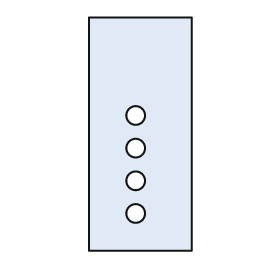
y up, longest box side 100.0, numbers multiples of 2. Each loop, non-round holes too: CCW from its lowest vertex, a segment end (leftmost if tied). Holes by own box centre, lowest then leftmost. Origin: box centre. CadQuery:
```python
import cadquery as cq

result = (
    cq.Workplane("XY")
    .moveTo(-22.0, -50.0)
    .lineTo(22.0, -50.0)
    .lineTo(22.0, 50.0)
    .lineTo(-22.0, 50.0)
    .close()
    .moveTo(-2.0, -34.0)
    .circle(4.0)
    .moveTo(-2.0, -20.0)
    .circle(4.0)
    .moveTo(-2.0, -6.0)
    .circle(4.0)
    .moveTo(-2.0, 8.0)
    .circle(4.0)
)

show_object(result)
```